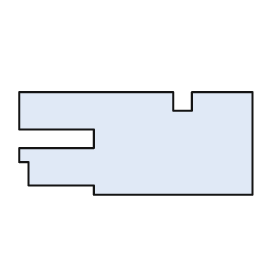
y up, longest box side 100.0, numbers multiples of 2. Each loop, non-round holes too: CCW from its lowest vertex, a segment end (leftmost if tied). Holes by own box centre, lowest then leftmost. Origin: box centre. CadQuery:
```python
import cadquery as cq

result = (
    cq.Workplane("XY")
    .moveTo(-18.0, -22.0)
    .lineTo(50.0, -22.0)
    .lineTo(50.0, 22.0)
    .lineTo(24.0, 22.0)
    .lineTo(24.0, 14.0)
    .lineTo(16.0, 14.0)
    .lineTo(16.0, 22.0)
    .lineTo(-50.0, 22.0)
    .lineTo(-50.0, 6.0)
    .lineTo(-18.0, 6.0)
    .lineTo(-18.0, -2.0)
    .lineTo(-50.0, -2.0)
    .lineTo(-50.0, -8.0)
    .lineTo(-46.0, -8.0)
    .lineTo(-46.0, -18.0)
    .lineTo(-18.0, -18.0)
    .close()
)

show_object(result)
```